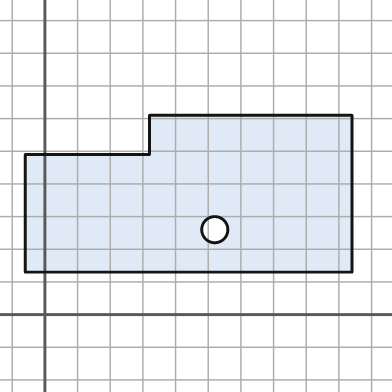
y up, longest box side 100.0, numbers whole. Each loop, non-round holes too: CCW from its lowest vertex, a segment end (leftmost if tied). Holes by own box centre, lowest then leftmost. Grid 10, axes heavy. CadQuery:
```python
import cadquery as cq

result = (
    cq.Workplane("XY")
    .moveTo(-6.0, 13.0)
    .lineTo(94.0, 13.0)
    .lineTo(94.0, 61.0)
    .lineTo(32.0, 61.0)
    .lineTo(32.0, 49.0)
    .lineTo(-6.0, 49.0)
    .close()
    .moveTo(52.0, 26.0)
    .circle(4.0)
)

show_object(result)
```